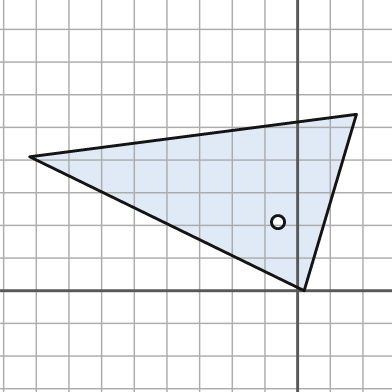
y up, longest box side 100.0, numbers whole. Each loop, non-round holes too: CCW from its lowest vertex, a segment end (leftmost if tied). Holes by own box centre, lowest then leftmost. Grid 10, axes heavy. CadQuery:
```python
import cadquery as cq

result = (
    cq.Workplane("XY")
    .moveTo(2.0, 0.0)
    .lineTo(18.0, 54.0)
    .lineTo(-82.0, 41.0)
    .close()
    .moveTo(-6.0, 21.0)
    .circle(2.0)
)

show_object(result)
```